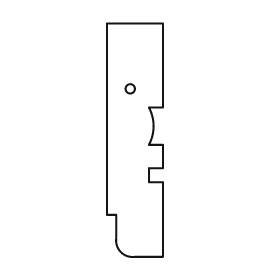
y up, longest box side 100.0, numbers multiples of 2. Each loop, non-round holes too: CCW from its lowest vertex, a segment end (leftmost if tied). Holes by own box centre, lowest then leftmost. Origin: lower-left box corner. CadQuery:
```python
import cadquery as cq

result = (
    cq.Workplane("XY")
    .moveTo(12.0, 0.0)
    .lineTo(24.0, 0.0)
    .lineTo(24.0, 32.0)
    .lineTo(18.0, 32.0)
    .lineTo(18.0, 38.0)
    .lineTo(24.0, 38.0)
    .lineTo(24.0, 48.0)
    .lineTo(18.0, 48.0)
    .threePointArc((20.0, 56.0), (18.0, 64.0))
    .lineTo(24.0, 64.0)
    .lineTo(24.0, 100.0)
    .lineTo(0.0, 100.0)
    .lineTo(0.0, 18.0)
    .lineTo(4.0, 18.0)
    .lineTo(4.0, 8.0)
    .threePointArc((6.0, 2.0), (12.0, 0.0))
    .close()
    .moveTo(10.0, 72.0)
    .circle(2.0)
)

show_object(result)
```